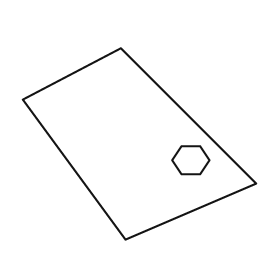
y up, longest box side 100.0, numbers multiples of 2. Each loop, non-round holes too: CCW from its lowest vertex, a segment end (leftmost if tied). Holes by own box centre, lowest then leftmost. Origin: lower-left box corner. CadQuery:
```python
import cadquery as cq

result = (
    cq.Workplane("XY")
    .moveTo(44.0, 0.0)
    .lineTo(100.0, 24.0)
    .lineTo(42.0, 82.0)
    .lineTo(0.0, 60.0)
    .close()
    .moveTo(68.0, 28.0)
    .lineTo(76.0, 28.0)
    .lineTo(80.0, 34.0)
    .lineTo(76.0, 40.0)
    .lineTo(68.0, 40.0)
    .lineTo(64.0, 34.0)
    .close()
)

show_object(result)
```